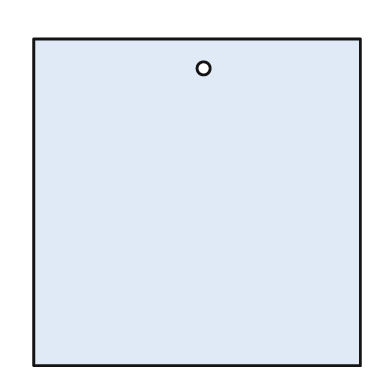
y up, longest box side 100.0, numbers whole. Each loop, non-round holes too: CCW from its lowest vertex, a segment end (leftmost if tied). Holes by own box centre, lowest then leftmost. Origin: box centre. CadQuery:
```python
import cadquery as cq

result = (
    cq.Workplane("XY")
    .moveTo(-50.0, -50.0)
    .lineTo(50.0, -50.0)
    .lineTo(50.0, 50.0)
    .lineTo(-50.0, 50.0)
    .close()
    .moveTo(2.0, 41.0)
    .circle(2.0)
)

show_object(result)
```